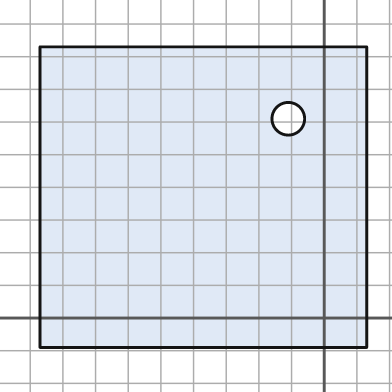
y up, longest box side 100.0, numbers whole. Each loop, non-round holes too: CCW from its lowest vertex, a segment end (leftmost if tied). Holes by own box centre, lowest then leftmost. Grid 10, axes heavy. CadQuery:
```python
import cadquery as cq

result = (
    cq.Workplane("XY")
    .moveTo(-87.0, -9.0)
    .lineTo(13.0, -9.0)
    .lineTo(13.0, 83.0)
    .lineTo(-87.0, 83.0)
    .close()
    .moveTo(-11.0, 61.0)
    .circle(5.0)
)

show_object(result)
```